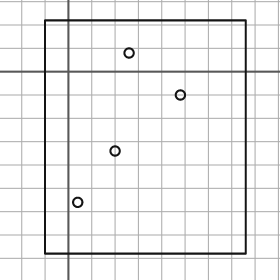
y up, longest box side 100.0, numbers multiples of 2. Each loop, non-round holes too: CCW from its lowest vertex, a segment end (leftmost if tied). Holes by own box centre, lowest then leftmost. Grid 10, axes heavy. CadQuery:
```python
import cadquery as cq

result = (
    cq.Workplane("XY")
    .moveTo(-10.0, -78.0)
    .lineTo(76.0, -78.0)
    .lineTo(76.0, 22.0)
    .lineTo(-10.0, 22.0)
    .close()
    .moveTo(4.0, -56.0)
    .circle(2.0)
    .moveTo(20.0, -34.0)
    .circle(2.0)
    .moveTo(48.0, -10.0)
    .circle(2.0)
    .moveTo(26.0, 8.0)
    .circle(2.0)
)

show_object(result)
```